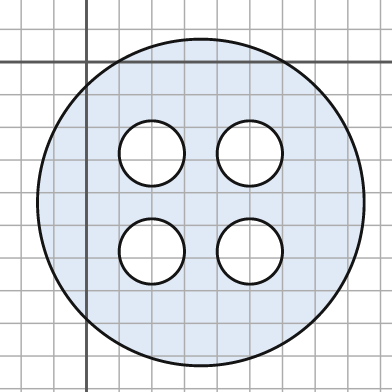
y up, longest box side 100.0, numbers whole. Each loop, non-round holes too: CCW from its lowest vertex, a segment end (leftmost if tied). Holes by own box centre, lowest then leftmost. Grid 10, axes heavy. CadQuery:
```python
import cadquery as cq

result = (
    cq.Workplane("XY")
    .moveTo(35.0, -43.0)
    .circle(50.0)
    .moveTo(20.0, -58.0)
    .circle(10.0)
    .moveTo(50.0, -58.0)
    .circle(10.0)
    .moveTo(20.0, -28.0)
    .circle(10.0)
    .moveTo(50.0, -28.0)
    .circle(10.0)
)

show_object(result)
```